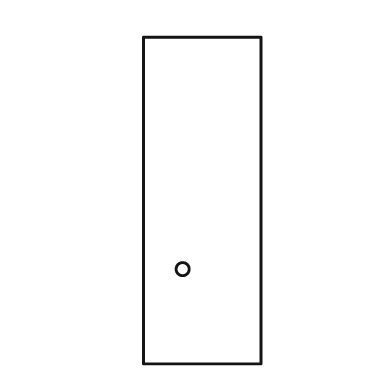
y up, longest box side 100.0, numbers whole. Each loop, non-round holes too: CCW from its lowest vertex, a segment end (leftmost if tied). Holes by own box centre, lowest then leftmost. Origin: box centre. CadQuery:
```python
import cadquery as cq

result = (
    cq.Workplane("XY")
    .moveTo(-18.0, -50.0)
    .lineTo(18.0, -50.0)
    .lineTo(18.0, 50.0)
    .lineTo(-18.0, 50.0)
    .close()
    .moveTo(-6.0, -21.0)
    .circle(2.0)
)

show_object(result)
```